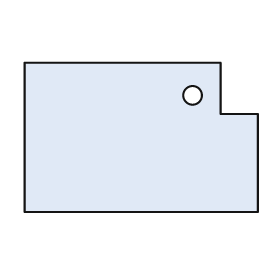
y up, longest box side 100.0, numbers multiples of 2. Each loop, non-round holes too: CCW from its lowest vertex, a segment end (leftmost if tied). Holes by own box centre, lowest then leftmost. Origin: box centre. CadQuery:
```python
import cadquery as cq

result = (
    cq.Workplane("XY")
    .moveTo(-50.0, -32.0)
    .lineTo(50.0, -32.0)
    .lineTo(50.0, 10.0)
    .lineTo(34.0, 10.0)
    .lineTo(34.0, 32.0)
    .lineTo(-50.0, 32.0)
    .close()
    .moveTo(22.0, 18.0)
    .circle(4.0)
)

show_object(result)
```